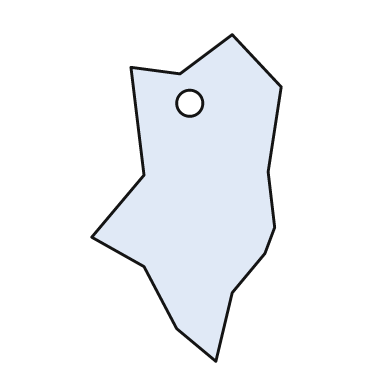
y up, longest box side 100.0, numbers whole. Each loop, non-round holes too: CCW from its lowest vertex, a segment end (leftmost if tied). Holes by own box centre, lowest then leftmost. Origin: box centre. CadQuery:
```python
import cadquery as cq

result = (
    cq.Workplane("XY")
    .moveTo(9.0, -50.0)
    .lineTo(14.0, -29.0)
    .lineTo(24.0, -17.0)
    .lineTo(27.0, -9.0)
    .lineTo(25.0, 8.0)
    .lineTo(29.0, 34.0)
    .lineTo(14.0, 50.0)
    .lineTo(-2.0, 38.0)
    .lineTo(-17.0, 40.0)
    .lineTo(-13.0, 7.0)
    .lineTo(-29.0, -12.0)
    .lineTo(-13.0, -21.0)
    .lineTo(-3.0, -40.0)
    .close()
    .moveTo(1.0, 29.0)
    .circle(4.0)
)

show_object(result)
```